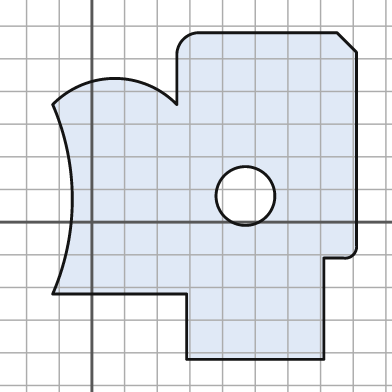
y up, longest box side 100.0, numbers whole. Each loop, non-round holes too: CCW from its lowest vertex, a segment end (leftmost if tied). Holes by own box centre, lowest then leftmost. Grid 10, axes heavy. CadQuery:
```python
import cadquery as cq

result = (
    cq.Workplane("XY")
    .moveTo(29.0, -42.0)
    .lineTo(71.0, -42.0)
    .lineTo(71.0, -11.0)
    .lineTo(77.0, -11.0)
    .threePointArc((80.0, -10.0), (81.0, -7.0))
    .lineTo(81.0, 52.0)
    .lineTo(75.0, 58.0)
    .lineTo(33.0, 58.0)
    .threePointArc((28.0, 56.0), (26.0, 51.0))
    .lineTo(26.0, 36.0)
    .threePointArc((7.0, 44.0), (-12.0, 36.0))
    .threePointArc((-6.0, 7.0), (-12.0, -22.0))
    .lineTo(29.0, -22.0)
    .close()
    .moveTo(47.0, 8.0)
    .circle(9.0)
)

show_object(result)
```